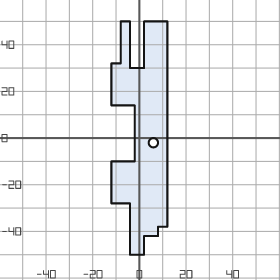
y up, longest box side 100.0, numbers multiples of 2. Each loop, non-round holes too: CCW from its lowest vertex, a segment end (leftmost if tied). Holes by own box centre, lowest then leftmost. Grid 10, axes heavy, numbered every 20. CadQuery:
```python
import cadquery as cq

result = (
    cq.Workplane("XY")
    .moveTo(-4.0, -50.0)
    .lineTo(2.0, -50.0)
    .lineTo(2.0, -42.0)
    .lineTo(8.0, -42.0)
    .lineTo(8.0, -38.0)
    .lineTo(12.0, -38.0)
    .lineTo(12.0, 50.0)
    .lineTo(2.0, 50.0)
    .lineTo(2.0, 30.0)
    .lineTo(-4.0, 30.0)
    .lineTo(-4.0, 50.0)
    .lineTo(-8.0, 50.0)
    .lineTo(-8.0, 32.0)
    .lineTo(-12.0, 32.0)
    .lineTo(-12.0, 14.0)
    .lineTo(-2.0, 14.0)
    .lineTo(-2.0, -10.0)
    .lineTo(-12.0, -10.0)
    .lineTo(-12.0, -28.0)
    .lineTo(-4.0, -28.0)
    .close()
    .moveTo(6.0, -2.0)
    .circle(2.0)
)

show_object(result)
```